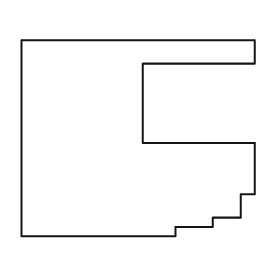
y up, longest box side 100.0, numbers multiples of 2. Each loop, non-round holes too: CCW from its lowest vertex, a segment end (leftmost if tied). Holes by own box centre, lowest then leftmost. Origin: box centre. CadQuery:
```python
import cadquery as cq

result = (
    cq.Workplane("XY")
    .moveTo(-50.0, -42.0)
    .lineTo(16.0, -42.0)
    .lineTo(16.0, -38.0)
    .lineTo(32.0, -38.0)
    .lineTo(32.0, -34.0)
    .lineTo(44.0, -34.0)
    .lineTo(44.0, -24.0)
    .lineTo(50.0, -24.0)
    .lineTo(50.0, -2.0)
    .lineTo(2.0, -2.0)
    .lineTo(2.0, 32.0)
    .lineTo(50.0, 32.0)
    .lineTo(50.0, 42.0)
    .lineTo(-50.0, 42.0)
    .close()
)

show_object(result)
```